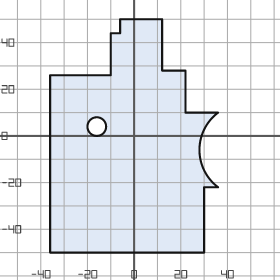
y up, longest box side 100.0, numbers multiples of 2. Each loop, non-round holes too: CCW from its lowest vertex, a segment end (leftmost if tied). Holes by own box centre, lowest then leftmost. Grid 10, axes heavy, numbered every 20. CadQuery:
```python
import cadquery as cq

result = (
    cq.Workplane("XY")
    .moveTo(-36.0, -50.0)
    .lineTo(30.0, -50.0)
    .lineTo(30.0, -22.0)
    .lineTo(36.0, -22.0)
    .threePointArc((28.0, -6.0), (36.0, 10.0))
    .lineTo(22.0, 10.0)
    .lineTo(22.0, 28.0)
    .lineTo(12.0, 28.0)
    .lineTo(12.0, 50.0)
    .lineTo(-6.0, 50.0)
    .lineTo(-6.0, 44.0)
    .lineTo(-10.0, 44.0)
    .lineTo(-10.0, 26.0)
    .lineTo(-36.0, 26.0)
    .close()
    .moveTo(-16.0, 4.0)
    .circle(4.0)
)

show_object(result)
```